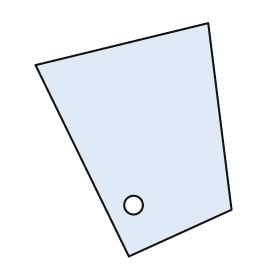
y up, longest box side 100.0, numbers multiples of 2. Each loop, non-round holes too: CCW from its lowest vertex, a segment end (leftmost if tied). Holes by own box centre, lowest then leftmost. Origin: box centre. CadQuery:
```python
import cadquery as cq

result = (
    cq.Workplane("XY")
    .moveTo(-2.0, -50.0)
    .lineTo(42.0, -30.0)
    .lineTo(32.0, 50.0)
    .lineTo(-42.0, 32.0)
    .close()
    .moveTo(0.0, -28.0)
    .circle(4.0)
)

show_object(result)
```